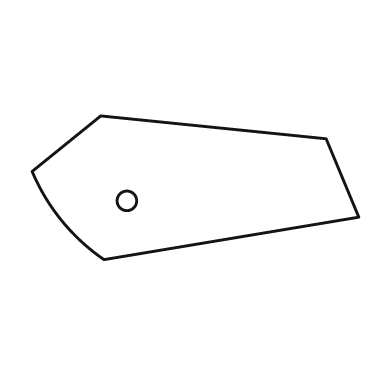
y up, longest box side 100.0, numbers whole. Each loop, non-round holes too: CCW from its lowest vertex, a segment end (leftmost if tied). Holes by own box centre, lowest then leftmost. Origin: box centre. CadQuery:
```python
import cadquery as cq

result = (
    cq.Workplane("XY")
    .moveTo(-28.0, -22.0)
    .lineTo(50.0, -9.0)
    .lineTo(40.0, 15.0)
    .lineTo(-29.0, 22.0)
    .lineTo(-50.0, 5.0)
    .threePointArc((-41.0, -10.0), (-28.0, -22.0))
    .close()
    .moveTo(-21.0, -4.0)
    .circle(3.0)
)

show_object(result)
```